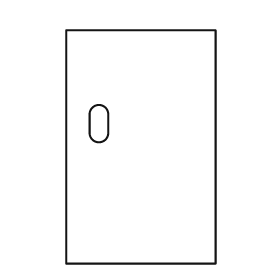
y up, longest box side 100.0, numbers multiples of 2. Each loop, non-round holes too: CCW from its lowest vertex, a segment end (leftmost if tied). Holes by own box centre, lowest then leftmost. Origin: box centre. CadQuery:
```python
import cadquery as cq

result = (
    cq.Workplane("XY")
    .moveTo(-32.0, -50.0)
    .lineTo(32.0, -50.0)
    .lineTo(32.0, 50.0)
    .lineTo(-32.0, 50.0)
    .close()
    .moveTo(-22.0, 6.0)
    .threePointArc((-18.0, 2.0), (-14.0, 6.0))
    .lineTo(-14.0, 14.0)
    .threePointArc((-18.0, 18.0), (-22.0, 14.0))
    .close()
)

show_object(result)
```